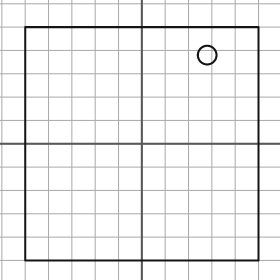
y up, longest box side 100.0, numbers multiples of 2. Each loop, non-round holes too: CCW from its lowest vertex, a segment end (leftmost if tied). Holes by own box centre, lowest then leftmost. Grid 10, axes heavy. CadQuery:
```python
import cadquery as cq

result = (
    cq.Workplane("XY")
    .moveTo(-50.0, -50.0)
    .lineTo(50.0, -50.0)
    .lineTo(50.0, 50.0)
    .lineTo(-50.0, 50.0)
    .close()
    .moveTo(28.0, 38.0)
    .circle(4.0)
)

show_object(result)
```